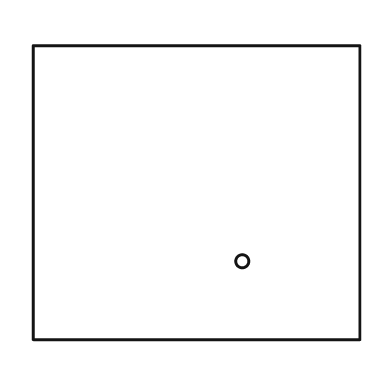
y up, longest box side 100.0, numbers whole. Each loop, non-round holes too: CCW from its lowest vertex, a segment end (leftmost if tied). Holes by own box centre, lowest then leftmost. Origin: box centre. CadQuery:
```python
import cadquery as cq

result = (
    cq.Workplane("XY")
    .moveTo(-50.0, -45.0)
    .lineTo(50.0, -45.0)
    .lineTo(50.0, 45.0)
    .lineTo(-50.0, 45.0)
    .close()
    .moveTo(14.0, -21.0)
    .circle(2.0)
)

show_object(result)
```